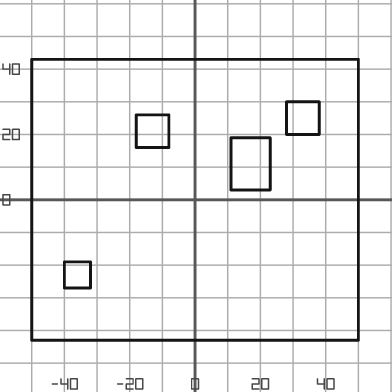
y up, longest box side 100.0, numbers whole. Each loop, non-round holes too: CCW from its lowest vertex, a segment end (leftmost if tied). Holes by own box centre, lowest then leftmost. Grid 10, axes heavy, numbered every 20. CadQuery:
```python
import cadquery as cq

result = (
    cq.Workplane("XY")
    .moveTo(-50.0, -43.0)
    .lineTo(50.0, -43.0)
    .lineTo(50.0, 43.0)
    .lineTo(-50.0, 43.0)
    .close()
    .moveTo(-40.0, -27.0)
    .lineTo(-32.0, -27.0)
    .lineTo(-32.0, -19.0)
    .lineTo(-40.0, -19.0)
    .close()
    .moveTo(11.0, 3.0)
    .lineTo(23.0, 3.0)
    .lineTo(23.0, 19.0)
    .lineTo(11.0, 19.0)
    .close()
    .moveTo(-18.0, 16.0)
    .lineTo(-8.0, 16.0)
    .lineTo(-8.0, 26.0)
    .lineTo(-18.0, 26.0)
    .close()
    .moveTo(28.0, 20.0)
    .lineTo(38.0, 20.0)
    .lineTo(38.0, 30.0)
    .lineTo(28.0, 30.0)
    .close()
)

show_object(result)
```